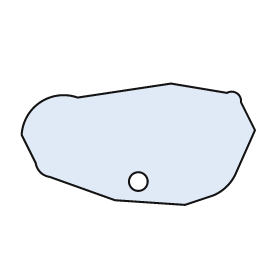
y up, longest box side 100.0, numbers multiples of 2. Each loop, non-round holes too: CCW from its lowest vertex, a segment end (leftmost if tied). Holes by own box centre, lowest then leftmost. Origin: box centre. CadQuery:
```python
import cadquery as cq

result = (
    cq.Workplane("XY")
    .moveTo(20.0, -26.0)
    .lineTo(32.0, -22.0)
    .threePointArc((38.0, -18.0), (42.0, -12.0))
    .lineTo(50.0, 6.0)
    .lineTo(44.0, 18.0)
    .threePointArc((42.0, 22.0), (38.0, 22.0))
    .lineTo(14.0, 26.0)
    .lineTo(-26.0, 20.0)
    .threePointArc((-42.0, 18.0), (-50.0, 4.0))
    .lineTo(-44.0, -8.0)
    .threePointArc((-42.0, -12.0), (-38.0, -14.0))
    .lineTo(-10.0, -24.0)
    .close()
    .moveTo(0.0, -16.0)
    .circle(4.0)
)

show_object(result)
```